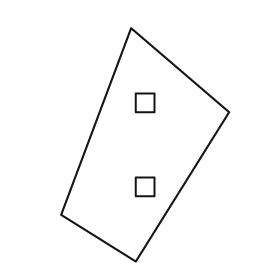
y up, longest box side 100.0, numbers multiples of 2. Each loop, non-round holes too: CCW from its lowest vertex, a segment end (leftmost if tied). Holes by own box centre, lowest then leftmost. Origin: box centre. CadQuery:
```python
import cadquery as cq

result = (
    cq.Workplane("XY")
    .moveTo(-4.0, -50.0)
    .lineTo(36.0, 14.0)
    .lineTo(-6.0, 50.0)
    .lineTo(-36.0, -30.0)
    .close()
    .moveTo(-4.0, -22.0)
    .lineTo(4.0, -22.0)
    .lineTo(4.0, -14.0)
    .lineTo(-4.0, -14.0)
    .close()
    .moveTo(-4.0, 14.0)
    .lineTo(4.0, 14.0)
    .lineTo(4.0, 22.0)
    .lineTo(-4.0, 22.0)
    .close()
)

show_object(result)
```